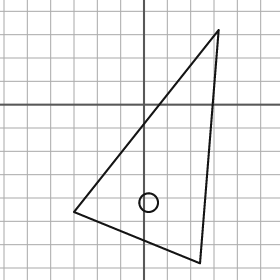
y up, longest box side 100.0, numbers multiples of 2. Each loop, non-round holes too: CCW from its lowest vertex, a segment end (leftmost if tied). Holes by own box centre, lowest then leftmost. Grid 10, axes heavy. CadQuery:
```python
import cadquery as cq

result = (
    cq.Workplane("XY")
    .moveTo(24.0, -68.0)
    .lineTo(32.0, 32.0)
    .lineTo(-30.0, -46.0)
    .close()
    .moveTo(2.0, -42.0)
    .circle(4.0)
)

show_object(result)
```